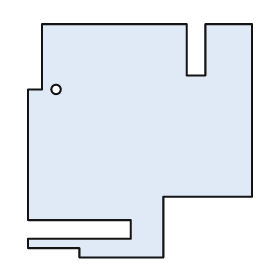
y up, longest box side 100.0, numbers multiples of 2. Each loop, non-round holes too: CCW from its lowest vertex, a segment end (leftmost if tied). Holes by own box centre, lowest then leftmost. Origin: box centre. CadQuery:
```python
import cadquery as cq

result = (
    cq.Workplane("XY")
    .moveTo(-26.0, -50.0)
    .lineTo(10.0, -50.0)
    .lineTo(10.0, -24.0)
    .lineTo(48.0, -24.0)
    .lineTo(48.0, 50.0)
    .lineTo(28.0, 50.0)
    .lineTo(28.0, 28.0)
    .lineTo(20.0, 28.0)
    .lineTo(20.0, 50.0)
    .lineTo(-42.0, 50.0)
    .lineTo(-42.0, 22.0)
    .lineTo(-48.0, 22.0)
    .lineTo(-48.0, -34.0)
    .lineTo(-4.0, -34.0)
    .lineTo(-4.0, -42.0)
    .lineTo(-48.0, -42.0)
    .lineTo(-48.0, -46.0)
    .lineTo(-26.0, -46.0)
    .close()
    .moveTo(-36.0, 22.0)
    .circle(2.0)
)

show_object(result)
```